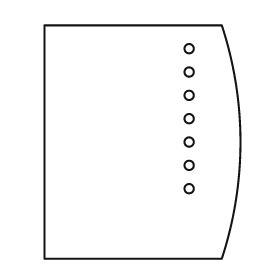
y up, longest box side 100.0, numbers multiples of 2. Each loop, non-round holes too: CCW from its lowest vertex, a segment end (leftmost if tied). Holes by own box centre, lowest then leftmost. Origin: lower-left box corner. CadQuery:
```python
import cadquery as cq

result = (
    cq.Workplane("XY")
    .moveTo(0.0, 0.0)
    .lineTo(76.0, 0.0)
    .threePointArc((84.0, 50.0), (76.0, 100.0))
    .lineTo(0.0, 100.0)
    .close()
    .moveTo(62.0, 30.0)
    .circle(2.0)
    .moveTo(62.0, 40.0)
    .circle(2.0)
    .moveTo(62.0, 50.0)
    .circle(2.0)
    .moveTo(62.0, 60.0)
    .circle(2.0)
    .moveTo(62.0, 70.0)
    .circle(2.0)
    .moveTo(62.0, 80.0)
    .circle(2.0)
    .moveTo(62.0, 90.0)
    .circle(2.0)
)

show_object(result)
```